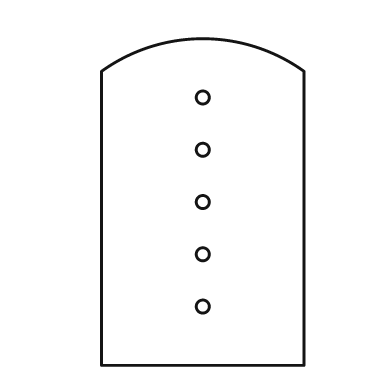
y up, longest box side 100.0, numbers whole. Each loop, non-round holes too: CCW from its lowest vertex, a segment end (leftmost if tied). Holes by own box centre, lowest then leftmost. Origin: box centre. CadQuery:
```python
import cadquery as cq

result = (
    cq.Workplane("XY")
    .moveTo(-31.0, -50.0)
    .lineTo(31.0, -50.0)
    .lineTo(31.0, 40.0)
    .threePointArc((0.0, 50.0), (-31.0, 40.0))
    .close()
    .moveTo(0.0, -32.0)
    .circle(2.0)
    .moveTo(0.0, -16.0)
    .circle(2.0)
    .moveTo(0.0, 0.0)
    .circle(2.0)
    .moveTo(0.0, 16.0)
    .circle(2.0)
    .moveTo(0.0, 32.0)
    .circle(2.0)
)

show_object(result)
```